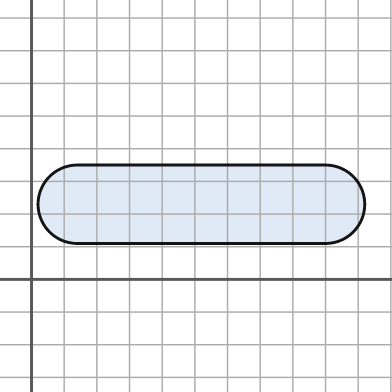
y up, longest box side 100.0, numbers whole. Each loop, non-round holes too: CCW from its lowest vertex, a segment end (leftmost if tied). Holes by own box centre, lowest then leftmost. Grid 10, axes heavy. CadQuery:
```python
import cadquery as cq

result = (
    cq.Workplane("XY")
    .moveTo(14.0, 11.0)
    .lineTo(90.0, 11.0)
    .threePointArc((102.0, 23.0), (90.0, 35.0))
    .lineTo(14.0, 35.0)
    .threePointArc((2.0, 23.0), (14.0, 11.0))
    .close()
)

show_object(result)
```